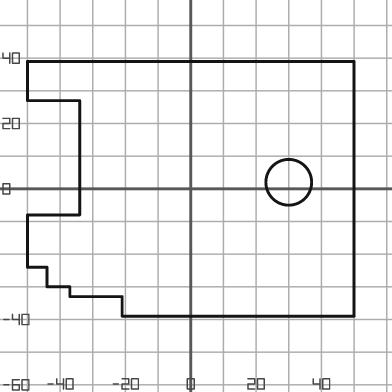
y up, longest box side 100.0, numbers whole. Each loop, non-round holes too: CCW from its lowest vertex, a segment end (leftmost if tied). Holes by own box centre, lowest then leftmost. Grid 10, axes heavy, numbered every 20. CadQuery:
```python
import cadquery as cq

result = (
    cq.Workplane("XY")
    .moveTo(-21.0, -39.0)
    .lineTo(50.0, -39.0)
    .lineTo(50.0, 39.0)
    .lineTo(-50.0, 39.0)
    .lineTo(-50.0, 27.0)
    .lineTo(-34.0, 27.0)
    .lineTo(-34.0, -8.0)
    .lineTo(-50.0, -8.0)
    .lineTo(-50.0, -24.0)
    .lineTo(-44.0, -24.0)
    .lineTo(-44.0, -30.0)
    .lineTo(-37.0, -30.0)
    .lineTo(-37.0, -33.0)
    .lineTo(-21.0, -33.0)
    .close()
    .moveTo(30.0, 2.0)
    .circle(7.0)
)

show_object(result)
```